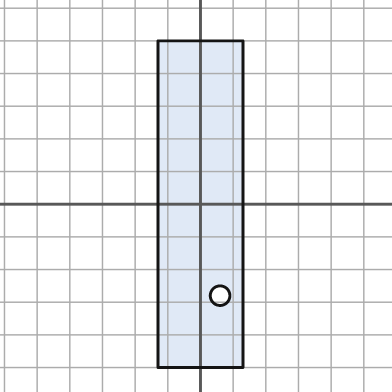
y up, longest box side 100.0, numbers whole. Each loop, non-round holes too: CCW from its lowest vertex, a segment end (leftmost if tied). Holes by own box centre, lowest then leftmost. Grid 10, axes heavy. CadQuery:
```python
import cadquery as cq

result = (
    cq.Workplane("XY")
    .moveTo(-13.0, -50.0)
    .lineTo(13.0, -50.0)
    .lineTo(13.0, 50.0)
    .lineTo(-13.0, 50.0)
    .close()
    .moveTo(6.0, -28.0)
    .circle(3.0)
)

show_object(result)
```